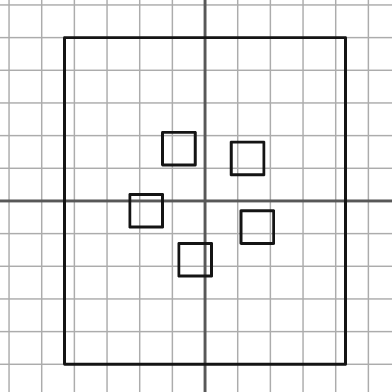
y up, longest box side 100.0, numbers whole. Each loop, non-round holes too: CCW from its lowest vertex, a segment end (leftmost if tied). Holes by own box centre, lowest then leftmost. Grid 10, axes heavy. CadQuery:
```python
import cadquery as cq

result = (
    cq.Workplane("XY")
    .moveTo(-43.0, -50.0)
    .lineTo(43.0, -50.0)
    .lineTo(43.0, 50.0)
    .lineTo(-43.0, 50.0)
    .close()
    .moveTo(-8.0, -23.0)
    .lineTo(2.0, -23.0)
    .lineTo(2.0, -13.0)
    .lineTo(-8.0, -13.0)
    .close()
    .moveTo(11.0, -13.0)
    .lineTo(21.0, -13.0)
    .lineTo(21.0, -3.0)
    .lineTo(11.0, -3.0)
    .close()
    .moveTo(-23.0, -8.0)
    .lineTo(-13.0, -8.0)
    .lineTo(-13.0, 2.0)
    .lineTo(-23.0, 2.0)
    .close()
    .moveTo(8.0, 8.0)
    .lineTo(18.0, 8.0)
    .lineTo(18.0, 18.0)
    .lineTo(8.0, 18.0)
    .close()
    .moveTo(-13.0, 11.0)
    .lineTo(-3.0, 11.0)
    .lineTo(-3.0, 21.0)
    .lineTo(-13.0, 21.0)
    .close()
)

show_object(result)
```